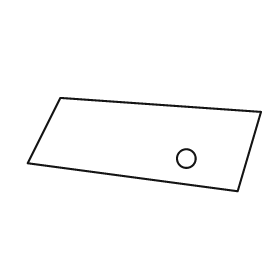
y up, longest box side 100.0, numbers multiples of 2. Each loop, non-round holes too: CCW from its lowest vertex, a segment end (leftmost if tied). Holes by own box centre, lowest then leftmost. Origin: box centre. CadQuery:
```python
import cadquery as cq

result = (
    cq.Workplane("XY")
    .moveTo(40.0, -20.0)
    .lineTo(50.0, 14.0)
    .lineTo(-36.0, 20.0)
    .lineTo(-50.0, -8.0)
    .close()
    .moveTo(18.0, -6.0)
    .circle(4.0)
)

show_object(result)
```